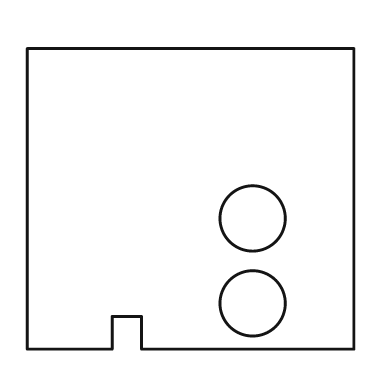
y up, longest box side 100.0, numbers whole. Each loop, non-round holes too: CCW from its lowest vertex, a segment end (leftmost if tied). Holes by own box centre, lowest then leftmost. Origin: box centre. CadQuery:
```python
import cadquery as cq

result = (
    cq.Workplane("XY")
    .moveTo(-50.0, -46.0)
    .lineTo(-24.0, -46.0)
    .lineTo(-24.0, -36.0)
    .lineTo(-15.0, -36.0)
    .lineTo(-15.0, -46.0)
    .lineTo(50.0, -46.0)
    .lineTo(50.0, 46.0)
    .lineTo(-50.0, 46.0)
    .close()
    .moveTo(19.0, -32.0)
    .circle(10.0)
    .moveTo(19.0, -6.0)
    .circle(10.0)
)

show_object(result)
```